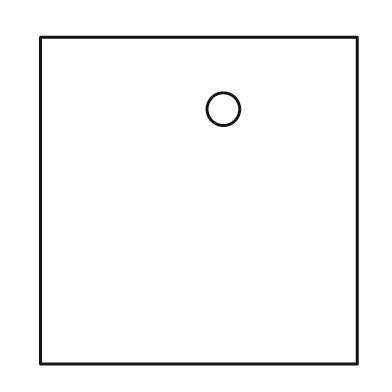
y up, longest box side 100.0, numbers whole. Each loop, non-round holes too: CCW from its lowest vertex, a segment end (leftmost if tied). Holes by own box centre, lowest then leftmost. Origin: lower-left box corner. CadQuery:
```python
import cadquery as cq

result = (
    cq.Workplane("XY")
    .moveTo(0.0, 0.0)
    .lineTo(97.0, 0.0)
    .lineTo(97.0, 100.0)
    .lineTo(0.0, 100.0)
    .close()
    .moveTo(56.0, 78.0)
    .circle(5.0)
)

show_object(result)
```